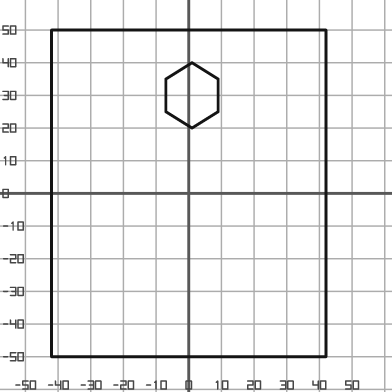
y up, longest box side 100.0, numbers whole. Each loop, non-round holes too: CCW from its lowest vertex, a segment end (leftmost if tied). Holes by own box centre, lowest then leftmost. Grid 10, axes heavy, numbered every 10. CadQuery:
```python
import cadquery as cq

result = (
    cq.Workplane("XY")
    .moveTo(-42.0, -50.0)
    .lineTo(42.0, -50.0)
    .lineTo(42.0, 50.0)
    .lineTo(-42.0, 50.0)
    .close()
    .moveTo(1.0, 20.0)
    .lineTo(9.0, 25.0)
    .lineTo(9.0, 35.0)
    .lineTo(1.0, 40.0)
    .lineTo(-7.0, 35.0)
    .lineTo(-7.0, 25.0)
    .close()
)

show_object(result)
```